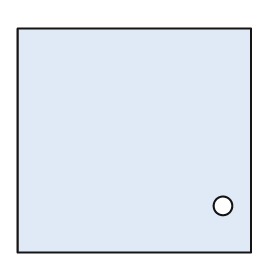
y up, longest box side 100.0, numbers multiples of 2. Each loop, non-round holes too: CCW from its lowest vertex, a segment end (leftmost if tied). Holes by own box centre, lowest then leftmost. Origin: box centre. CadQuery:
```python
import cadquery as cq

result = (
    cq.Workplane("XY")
    .moveTo(-50.0, -48.0)
    .lineTo(50.0, -48.0)
    .lineTo(50.0, 48.0)
    .lineTo(-50.0, 48.0)
    .close()
    .moveTo(38.0, -28.0)
    .circle(4.0)
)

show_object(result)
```